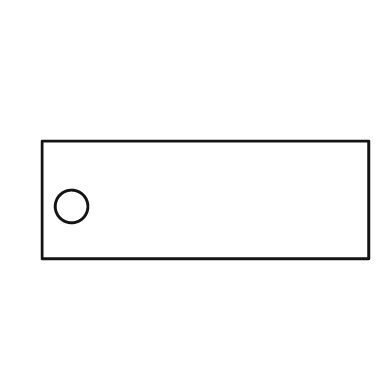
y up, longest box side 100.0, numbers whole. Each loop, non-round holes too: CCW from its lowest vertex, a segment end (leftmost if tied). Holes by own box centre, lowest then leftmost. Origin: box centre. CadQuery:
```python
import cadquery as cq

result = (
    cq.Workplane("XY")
    .moveTo(-50.0, -18.0)
    .lineTo(50.0, -18.0)
    .lineTo(50.0, 18.0)
    .lineTo(-50.0, 18.0)
    .close()
    .moveTo(-41.0, -2.0)
    .circle(5.0)
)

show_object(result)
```